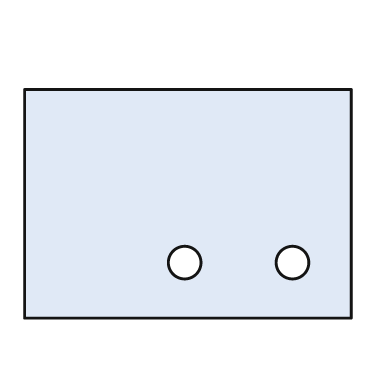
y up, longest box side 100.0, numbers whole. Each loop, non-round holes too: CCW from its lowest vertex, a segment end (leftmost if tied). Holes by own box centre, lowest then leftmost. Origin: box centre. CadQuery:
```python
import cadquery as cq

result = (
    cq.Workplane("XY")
    .moveTo(-50.0, -35.0)
    .lineTo(50.0, -35.0)
    .lineTo(50.0, 35.0)
    .lineTo(-50.0, 35.0)
    .close()
    .moveTo(-1.0, -18.0)
    .circle(5.0)
    .moveTo(32.0, -18.0)
    .circle(5.0)
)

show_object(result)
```